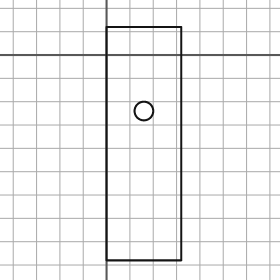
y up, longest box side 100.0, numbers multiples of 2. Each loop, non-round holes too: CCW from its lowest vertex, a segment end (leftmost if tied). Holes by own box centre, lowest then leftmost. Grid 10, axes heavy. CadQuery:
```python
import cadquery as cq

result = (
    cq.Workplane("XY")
    .moveTo(0.0, -88.0)
    .lineTo(32.0, -88.0)
    .lineTo(32.0, 12.0)
    .lineTo(0.0, 12.0)
    .close()
    .moveTo(16.0, -24.0)
    .circle(4.0)
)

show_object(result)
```